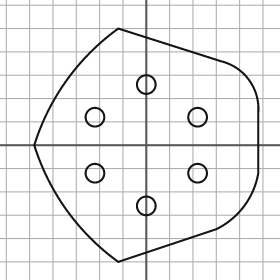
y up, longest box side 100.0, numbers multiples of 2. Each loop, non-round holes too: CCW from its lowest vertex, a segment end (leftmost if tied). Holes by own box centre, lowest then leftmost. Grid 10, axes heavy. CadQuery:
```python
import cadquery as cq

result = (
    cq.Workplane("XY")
    .moveTo(-12.0, -50.0)
    .lineTo(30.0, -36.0)
    .threePointArc((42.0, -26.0), (48.0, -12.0))
    .lineTo(48.0, 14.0)
    .threePointArc((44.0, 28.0), (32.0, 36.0))
    .lineTo(-12.0, 50.0)
    .threePointArc((-34.0, 28.0), (-48.0, 0.0))
    .threePointArc((-34.0, -28.0), (-12.0, -50.0))
    .close()
    .moveTo(0.0, -26.0)
    .circle(4.0)
    .moveTo(-22.0, -12.0)
    .circle(4.0)
    .moveTo(22.0, -12.0)
    .circle(4.0)
    .moveTo(-22.0, 12.0)
    .circle(4.0)
    .moveTo(22.0, 12.0)
    .circle(4.0)
    .moveTo(0.0, 26.0)
    .circle(4.0)
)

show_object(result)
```